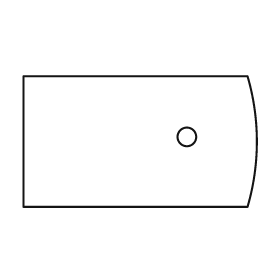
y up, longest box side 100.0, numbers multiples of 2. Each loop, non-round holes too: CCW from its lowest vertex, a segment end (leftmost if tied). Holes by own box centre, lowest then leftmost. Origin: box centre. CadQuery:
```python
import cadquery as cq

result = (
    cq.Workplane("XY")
    .moveTo(-50.0, -28.0)
    .lineTo(46.0, -28.0)
    .threePointArc((50.0, 0.0), (46.0, 28.0))
    .lineTo(-50.0, 28.0)
    .close()
    .moveTo(20.0, 2.0)
    .circle(4.0)
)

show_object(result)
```